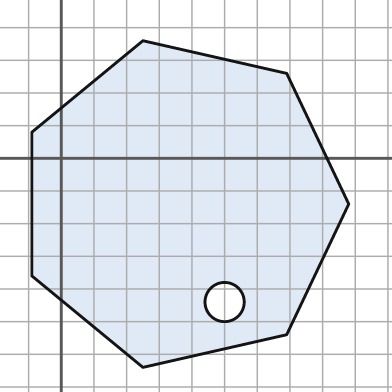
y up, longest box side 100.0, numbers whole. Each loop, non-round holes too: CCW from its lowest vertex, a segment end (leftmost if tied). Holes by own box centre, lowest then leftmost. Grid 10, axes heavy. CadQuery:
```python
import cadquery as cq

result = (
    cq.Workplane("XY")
    .moveTo(25.0, -64.0)
    .lineTo(69.0, -54.0)
    .lineTo(88.0, -14.0)
    .lineTo(69.0, 26.0)
    .lineTo(25.0, 36.0)
    .lineTo(-9.0, 8.0)
    .lineTo(-9.0, -36.0)
    .close()
    .moveTo(50.0, -44.0)
    .circle(6.0)
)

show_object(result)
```